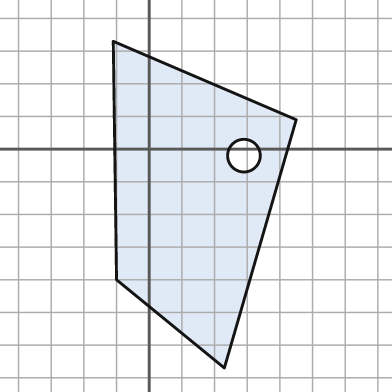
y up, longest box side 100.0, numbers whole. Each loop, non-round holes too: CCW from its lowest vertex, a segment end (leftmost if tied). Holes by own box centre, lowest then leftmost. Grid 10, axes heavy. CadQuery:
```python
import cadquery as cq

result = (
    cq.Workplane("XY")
    .moveTo(23.0, -67.0)
    .lineTo(45.0, 9.0)
    .lineTo(-11.0, 33.0)
    .lineTo(-10.0, -40.0)
    .close()
    .moveTo(29.0, -2.0)
    .circle(5.0)
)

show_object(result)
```